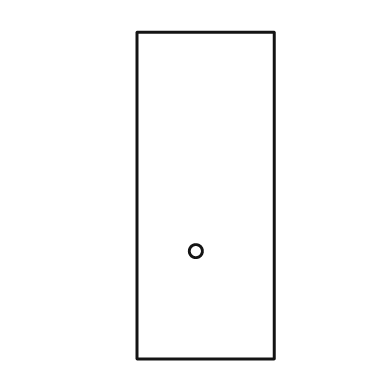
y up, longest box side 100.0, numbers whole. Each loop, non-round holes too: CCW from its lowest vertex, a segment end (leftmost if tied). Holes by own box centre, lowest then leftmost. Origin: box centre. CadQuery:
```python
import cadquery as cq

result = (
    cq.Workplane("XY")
    .moveTo(-21.0, -50.0)
    .lineTo(21.0, -50.0)
    .lineTo(21.0, 50.0)
    .lineTo(-21.0, 50.0)
    .close()
    .moveTo(-3.0, -17.0)
    .circle(2.0)
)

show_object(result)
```